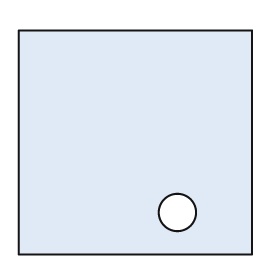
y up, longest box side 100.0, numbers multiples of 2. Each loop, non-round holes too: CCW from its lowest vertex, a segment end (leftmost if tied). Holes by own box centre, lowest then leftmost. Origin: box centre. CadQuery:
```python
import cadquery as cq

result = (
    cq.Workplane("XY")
    .moveTo(-50.0, -48.0)
    .lineTo(50.0, -48.0)
    .lineTo(50.0, 48.0)
    .lineTo(-50.0, 48.0)
    .close()
    .moveTo(18.0, -30.0)
    .circle(8.0)
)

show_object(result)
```